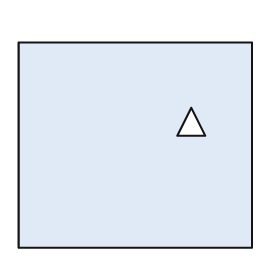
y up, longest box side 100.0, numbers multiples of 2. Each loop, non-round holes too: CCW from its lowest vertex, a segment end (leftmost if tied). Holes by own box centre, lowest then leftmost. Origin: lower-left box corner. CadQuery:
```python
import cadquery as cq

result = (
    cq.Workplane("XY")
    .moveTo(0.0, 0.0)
    .lineTo(100.0, 0.0)
    .lineTo(100.0, 88.0)
    .lineTo(0.0, 88.0)
    .close()
    .moveTo(68.0, 48.0)
    .lineTo(80.0, 48.0)
    .lineTo(74.0, 60.0)
    .close()
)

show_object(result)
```